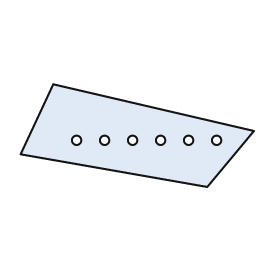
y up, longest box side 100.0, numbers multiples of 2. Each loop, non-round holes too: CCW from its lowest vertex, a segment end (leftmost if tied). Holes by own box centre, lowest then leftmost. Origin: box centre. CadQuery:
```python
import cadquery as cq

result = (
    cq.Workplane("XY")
    .moveTo(30.0, -22.0)
    .lineTo(50.0, 2.0)
    .lineTo(-36.0, 22.0)
    .lineTo(-50.0, -8.0)
    .close()
    .moveTo(-26.0, -2.0)
    .circle(2.0)
    .moveTo(-14.0, -2.0)
    .circle(2.0)
    .moveTo(-2.0, -2.0)
    .circle(2.0)
    .moveTo(10.0, -2.0)
    .circle(2.0)
    .moveTo(22.0, -2.0)
    .circle(2.0)
    .moveTo(34.0, -2.0)
    .circle(2.0)
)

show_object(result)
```